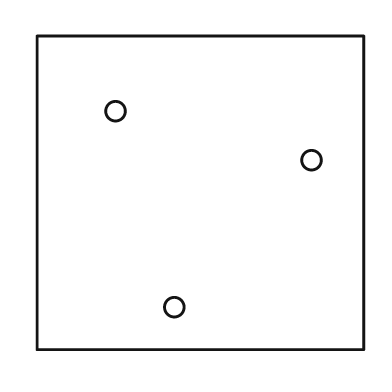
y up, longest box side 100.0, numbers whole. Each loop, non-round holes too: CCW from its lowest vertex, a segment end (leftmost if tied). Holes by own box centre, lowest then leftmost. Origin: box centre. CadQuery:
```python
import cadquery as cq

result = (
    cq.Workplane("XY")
    .moveTo(-50.0, -48.0)
    .lineTo(50.0, -48.0)
    .lineTo(50.0, 48.0)
    .lineTo(-50.0, 48.0)
    .close()
    .moveTo(-8.0, -35.0)
    .circle(3.0)
    .moveTo(34.0, 10.0)
    .circle(3.0)
    .moveTo(-26.0, 25.0)
    .circle(3.0)
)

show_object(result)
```